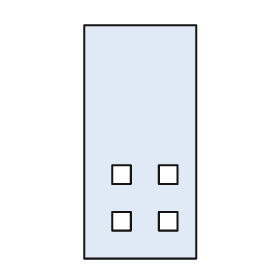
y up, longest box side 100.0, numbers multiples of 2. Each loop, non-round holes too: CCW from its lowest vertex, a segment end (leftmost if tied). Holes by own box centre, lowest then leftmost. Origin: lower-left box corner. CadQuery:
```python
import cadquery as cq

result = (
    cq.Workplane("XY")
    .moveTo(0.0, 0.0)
    .lineTo(48.0, 0.0)
    .lineTo(48.0, 100.0)
    .lineTo(0.0, 100.0)
    .close()
    .moveTo(12.0, 12.0)
    .lineTo(20.0, 12.0)
    .lineTo(20.0, 20.0)
    .lineTo(12.0, 20.0)
    .close()
    .moveTo(32.0, 12.0)
    .lineTo(40.0, 12.0)
    .lineTo(40.0, 20.0)
    .lineTo(32.0, 20.0)
    .close()
    .moveTo(12.0, 32.0)
    .lineTo(20.0, 32.0)
    .lineTo(20.0, 40.0)
    .lineTo(12.0, 40.0)
    .close()
    .moveTo(32.0, 32.0)
    .lineTo(40.0, 32.0)
    .lineTo(40.0, 40.0)
    .lineTo(32.0, 40.0)
    .close()
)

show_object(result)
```